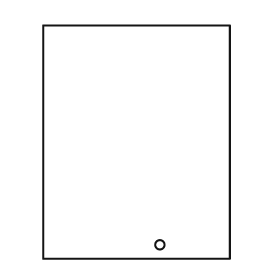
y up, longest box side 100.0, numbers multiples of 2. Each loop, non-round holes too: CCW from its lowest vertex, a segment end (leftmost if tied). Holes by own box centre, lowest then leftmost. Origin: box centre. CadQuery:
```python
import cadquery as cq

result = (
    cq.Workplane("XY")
    .moveTo(-40.0, -50.0)
    .lineTo(40.0, -50.0)
    .lineTo(40.0, 50.0)
    .lineTo(-40.0, 50.0)
    .close()
    .moveTo(10.0, -44.0)
    .circle(2.0)
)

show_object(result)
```